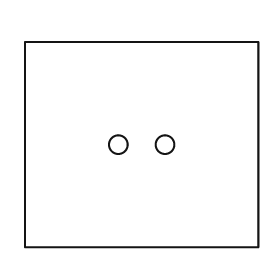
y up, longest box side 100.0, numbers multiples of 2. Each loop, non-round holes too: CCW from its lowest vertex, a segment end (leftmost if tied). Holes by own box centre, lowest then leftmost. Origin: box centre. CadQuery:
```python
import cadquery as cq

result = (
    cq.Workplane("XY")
    .moveTo(-50.0, -44.0)
    .lineTo(50.0, -44.0)
    .lineTo(50.0, 44.0)
    .lineTo(-50.0, 44.0)
    .close()
    .moveTo(-10.0, 0.0)
    .circle(4.0)
    .moveTo(10.0, 0.0)
    .circle(4.0)
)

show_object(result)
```